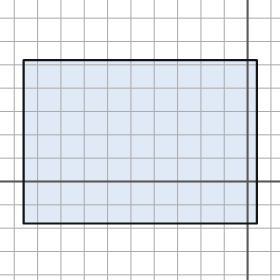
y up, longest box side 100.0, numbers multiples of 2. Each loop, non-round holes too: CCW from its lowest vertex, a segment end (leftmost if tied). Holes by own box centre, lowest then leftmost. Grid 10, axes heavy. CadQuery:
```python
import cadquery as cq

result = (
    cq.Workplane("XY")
    .moveTo(-96.0, -18.0)
    .lineTo(4.0, -18.0)
    .lineTo(4.0, 52.0)
    .lineTo(-96.0, 52.0)
    .close()
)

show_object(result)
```